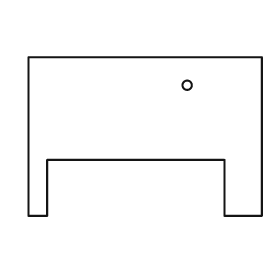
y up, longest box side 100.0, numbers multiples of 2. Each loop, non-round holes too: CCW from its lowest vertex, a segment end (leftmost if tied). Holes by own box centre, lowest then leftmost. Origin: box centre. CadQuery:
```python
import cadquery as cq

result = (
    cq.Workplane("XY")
    .moveTo(-50.0, -34.0)
    .lineTo(-42.0, -34.0)
    .lineTo(-42.0, -10.0)
    .lineTo(34.0, -10.0)
    .lineTo(34.0, -34.0)
    .lineTo(50.0, -34.0)
    .lineTo(50.0, 34.0)
    .lineTo(-50.0, 34.0)
    .close()
    .moveTo(18.0, 22.0)
    .circle(2.0)
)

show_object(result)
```